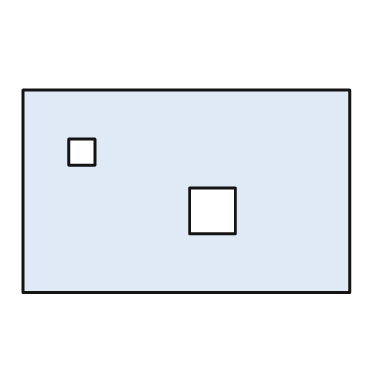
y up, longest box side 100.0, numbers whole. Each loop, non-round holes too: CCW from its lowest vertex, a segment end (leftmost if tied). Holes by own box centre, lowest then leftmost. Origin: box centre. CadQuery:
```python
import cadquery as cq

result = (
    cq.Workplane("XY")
    .moveTo(-50.0, -31.0)
    .lineTo(50.0, -31.0)
    .lineTo(50.0, 31.0)
    .lineTo(-50.0, 31.0)
    .close()
    .moveTo(1.0, -13.0)
    .lineTo(15.0, -13.0)
    .lineTo(15.0, 1.0)
    .lineTo(1.0, 1.0)
    .close()
    .moveTo(-36.0, 8.0)
    .lineTo(-28.0, 8.0)
    .lineTo(-28.0, 16.0)
    .lineTo(-36.0, 16.0)
    .close()
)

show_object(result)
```